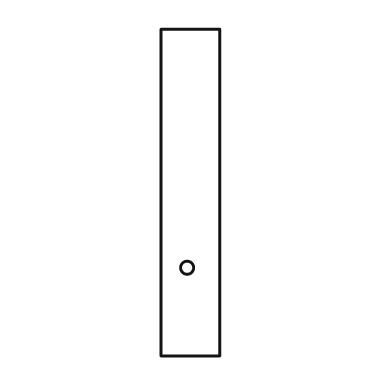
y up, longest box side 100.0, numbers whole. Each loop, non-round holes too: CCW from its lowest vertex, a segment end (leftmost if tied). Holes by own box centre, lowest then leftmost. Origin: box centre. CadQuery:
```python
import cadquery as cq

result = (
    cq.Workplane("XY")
    .moveTo(-9.0, -50.0)
    .lineTo(9.0, -50.0)
    .lineTo(9.0, 50.0)
    .lineTo(-9.0, 50.0)
    .close()
    .moveTo(-1.0, -23.0)
    .circle(2.0)
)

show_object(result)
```